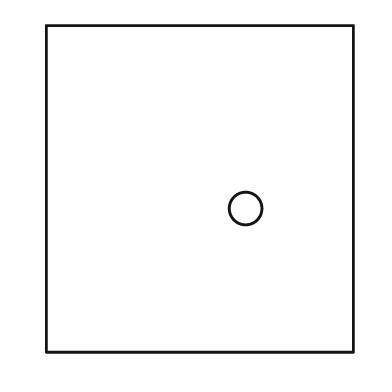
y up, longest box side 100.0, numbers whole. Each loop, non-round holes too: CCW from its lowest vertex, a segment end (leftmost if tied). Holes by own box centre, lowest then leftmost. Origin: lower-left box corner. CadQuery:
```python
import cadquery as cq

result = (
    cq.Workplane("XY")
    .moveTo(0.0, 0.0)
    .lineTo(94.0, 0.0)
    .lineTo(94.0, 100.0)
    .lineTo(0.0, 100.0)
    .close()
    .moveTo(61.0, 44.0)
    .circle(5.0)
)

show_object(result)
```